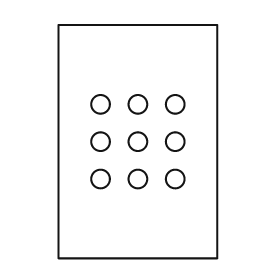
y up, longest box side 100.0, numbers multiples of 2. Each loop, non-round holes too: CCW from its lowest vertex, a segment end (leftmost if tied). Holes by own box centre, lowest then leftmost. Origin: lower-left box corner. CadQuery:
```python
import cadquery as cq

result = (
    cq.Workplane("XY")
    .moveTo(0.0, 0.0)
    .lineTo(68.0, 0.0)
    .lineTo(68.0, 100.0)
    .lineTo(0.0, 100.0)
    .close()
    .moveTo(18.0, 34.0)
    .circle(4.0)
    .moveTo(34.0, 34.0)
    .circle(4.0)
    .moveTo(50.0, 34.0)
    .circle(4.0)
    .moveTo(18.0, 50.0)
    .circle(4.0)
    .moveTo(34.0, 50.0)
    .circle(4.0)
    .moveTo(50.0, 50.0)
    .circle(4.0)
    .moveTo(18.0, 66.0)
    .circle(4.0)
    .moveTo(34.0, 66.0)
    .circle(4.0)
    .moveTo(50.0, 66.0)
    .circle(4.0)
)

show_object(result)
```